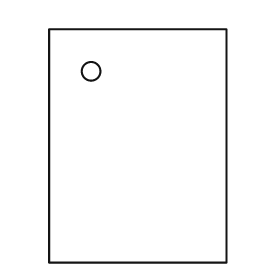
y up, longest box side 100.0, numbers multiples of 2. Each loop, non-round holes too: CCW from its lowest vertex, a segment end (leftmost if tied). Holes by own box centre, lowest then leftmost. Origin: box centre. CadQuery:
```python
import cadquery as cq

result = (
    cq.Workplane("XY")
    .moveTo(-38.0, -50.0)
    .lineTo(38.0, -50.0)
    .lineTo(38.0, 50.0)
    .lineTo(-38.0, 50.0)
    .close()
    .moveTo(-20.0, 32.0)
    .circle(4.0)
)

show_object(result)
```